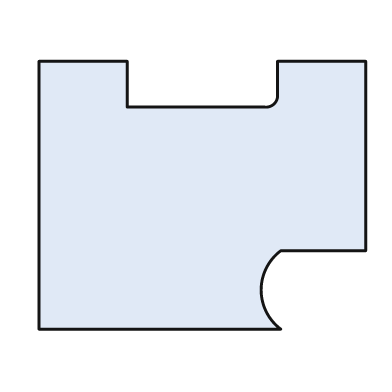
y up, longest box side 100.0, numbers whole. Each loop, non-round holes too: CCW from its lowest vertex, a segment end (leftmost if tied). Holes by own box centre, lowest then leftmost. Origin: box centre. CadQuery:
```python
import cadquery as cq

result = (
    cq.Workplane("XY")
    .moveTo(-50.0, -41.0)
    .lineTo(24.0, -41.0)
    .threePointArc((18.0, -29.0), (24.0, -17.0))
    .lineTo(50.0, -17.0)
    .lineTo(50.0, 41.0)
    .lineTo(23.0, 41.0)
    .lineTo(23.0, 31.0)
    .threePointArc((22.0, 28.0), (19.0, 27.0))
    .lineTo(-23.0, 27.0)
    .lineTo(-23.0, 41.0)
    .lineTo(-50.0, 41.0)
    .close()
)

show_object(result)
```